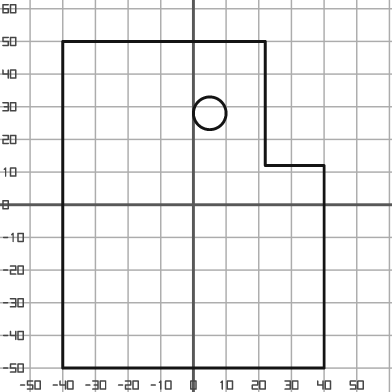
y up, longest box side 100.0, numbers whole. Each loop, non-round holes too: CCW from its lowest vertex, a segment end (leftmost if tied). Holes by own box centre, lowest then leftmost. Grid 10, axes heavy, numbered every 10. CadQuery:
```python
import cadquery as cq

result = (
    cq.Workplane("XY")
    .moveTo(-40.0, -50.0)
    .lineTo(40.0, -50.0)
    .lineTo(40.0, 12.0)
    .lineTo(22.0, 12.0)
    .lineTo(22.0, 50.0)
    .lineTo(-40.0, 50.0)
    .close()
    .moveTo(5.0, 28.0)
    .circle(5.0)
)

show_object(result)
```